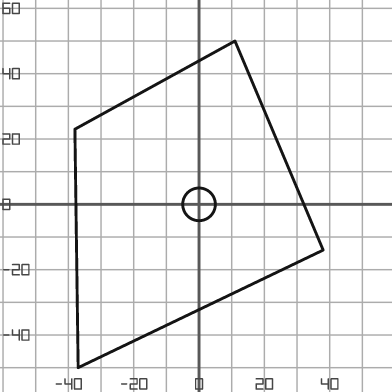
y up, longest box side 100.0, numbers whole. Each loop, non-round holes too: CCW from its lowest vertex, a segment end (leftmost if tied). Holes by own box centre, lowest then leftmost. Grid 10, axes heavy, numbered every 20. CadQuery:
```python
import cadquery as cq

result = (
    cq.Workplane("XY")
    .moveTo(-37.0, -50.0)
    .lineTo(38.0, -14.0)
    .lineTo(11.0, 50.0)
    .lineTo(-38.0, 23.0)
    .close()
    .moveTo(0.0, 0.0)
    .circle(5.0)
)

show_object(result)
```